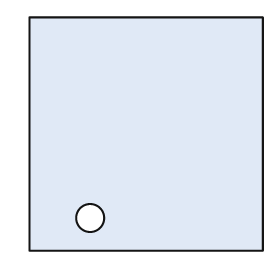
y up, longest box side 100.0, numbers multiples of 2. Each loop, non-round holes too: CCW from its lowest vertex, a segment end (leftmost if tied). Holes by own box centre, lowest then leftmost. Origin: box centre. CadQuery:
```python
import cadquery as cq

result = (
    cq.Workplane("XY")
    .moveTo(-50.0, -50.0)
    .lineTo(50.0, -50.0)
    .lineTo(50.0, 50.0)
    .lineTo(-50.0, 50.0)
    .close()
    .moveTo(-24.0, -36.0)
    .circle(6.0)
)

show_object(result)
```